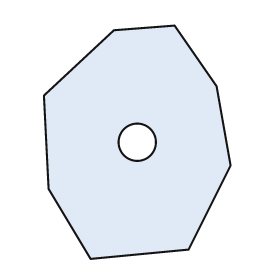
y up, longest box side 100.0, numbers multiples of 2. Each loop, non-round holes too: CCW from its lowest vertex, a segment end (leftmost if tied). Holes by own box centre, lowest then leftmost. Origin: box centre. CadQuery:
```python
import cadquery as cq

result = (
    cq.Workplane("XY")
    .moveTo(-20.0, -50.0)
    .lineTo(22.0, -46.0)
    .lineTo(40.0, -10.0)
    .lineTo(34.0, 24.0)
    .lineTo(16.0, 50.0)
    .lineTo(-10.0, 48.0)
    .lineTo(-40.0, 20.0)
    .lineTo(-38.0, -20.0)
    .close()
    .moveTo(0.0, 0.0)
    .circle(8.0)
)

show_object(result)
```